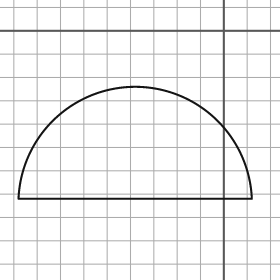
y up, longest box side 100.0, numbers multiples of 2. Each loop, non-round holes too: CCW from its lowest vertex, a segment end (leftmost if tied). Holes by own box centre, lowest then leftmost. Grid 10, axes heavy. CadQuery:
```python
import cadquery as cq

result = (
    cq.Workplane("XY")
    .moveTo(-88.0, -72.0)
    .lineTo(12.0, -72.0)
    .threePointArc((-38.0, -24.0), (-88.0, -72.0))
    .close()
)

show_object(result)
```